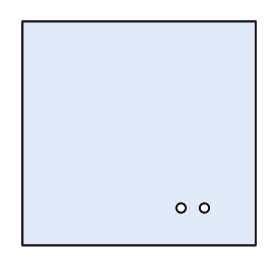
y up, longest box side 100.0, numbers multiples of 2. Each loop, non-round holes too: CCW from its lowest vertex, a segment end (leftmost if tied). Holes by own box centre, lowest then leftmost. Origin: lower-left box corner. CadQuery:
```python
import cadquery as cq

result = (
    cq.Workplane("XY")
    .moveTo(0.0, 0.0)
    .lineTo(100.0, 0.0)
    .lineTo(100.0, 96.0)
    .lineTo(0.0, 96.0)
    .close()
    .moveTo(68.0, 16.0)
    .circle(2.0)
    .moveTo(78.0, 16.0)
    .circle(2.0)
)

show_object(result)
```